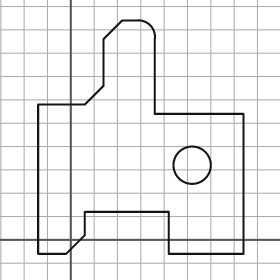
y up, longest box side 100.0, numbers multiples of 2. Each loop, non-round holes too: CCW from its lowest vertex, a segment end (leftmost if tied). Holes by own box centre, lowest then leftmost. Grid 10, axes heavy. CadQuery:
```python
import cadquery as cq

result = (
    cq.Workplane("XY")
    .moveTo(-14.0, -6.0)
    .lineTo(-2.0, -6.0)
    .lineTo(6.0, 2.0)
    .lineTo(6.0, 12.0)
    .lineTo(42.0, 12.0)
    .lineTo(42.0, -6.0)
    .lineTo(74.0, -6.0)
    .lineTo(74.0, 54.0)
    .lineTo(36.0, 54.0)
    .lineTo(36.0, 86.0)
    .threePointArc((34.0, 92.0), (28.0, 94.0))
    .lineTo(22.0, 94.0)
    .lineTo(14.0, 86.0)
    .lineTo(14.0, 66.0)
    .lineTo(6.0, 58.0)
    .lineTo(-14.0, 58.0)
    .close()
    .moveTo(52.0, 32.0)
    .circle(8.0)
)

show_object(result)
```